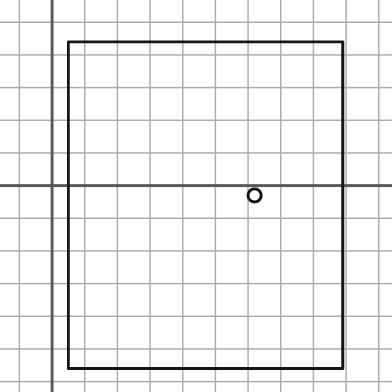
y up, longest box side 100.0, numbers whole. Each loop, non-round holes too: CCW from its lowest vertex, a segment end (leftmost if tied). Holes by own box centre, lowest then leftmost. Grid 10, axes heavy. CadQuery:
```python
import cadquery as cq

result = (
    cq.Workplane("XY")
    .moveTo(5.0, -56.0)
    .lineTo(89.0, -56.0)
    .lineTo(89.0, 44.0)
    .lineTo(5.0, 44.0)
    .close()
    .moveTo(62.0, -3.0)
    .circle(2.0)
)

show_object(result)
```